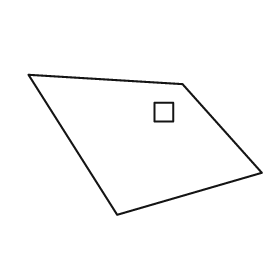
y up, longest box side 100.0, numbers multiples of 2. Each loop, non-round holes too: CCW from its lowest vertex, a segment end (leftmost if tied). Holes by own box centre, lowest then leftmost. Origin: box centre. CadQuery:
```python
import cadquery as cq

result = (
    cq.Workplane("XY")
    .moveTo(-12.0, -30.0)
    .lineTo(50.0, -12.0)
    .lineTo(16.0, 26.0)
    .lineTo(-50.0, 30.0)
    .close()
    .moveTo(4.0, 10.0)
    .lineTo(12.0, 10.0)
    .lineTo(12.0, 18.0)
    .lineTo(4.0, 18.0)
    .close()
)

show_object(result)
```